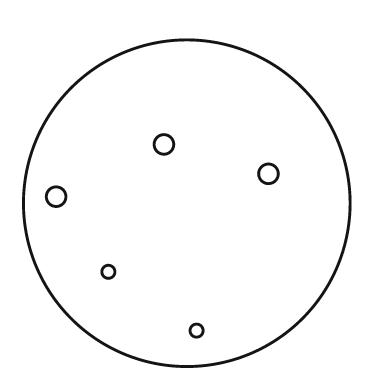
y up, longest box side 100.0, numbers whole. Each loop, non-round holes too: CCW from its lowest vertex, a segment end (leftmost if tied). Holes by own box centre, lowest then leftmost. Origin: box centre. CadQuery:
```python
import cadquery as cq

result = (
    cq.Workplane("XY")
    .moveTo(0.0, 0.0)
    .circle(50.0)
    .moveTo(3.0, -39.0)
    .circle(2.0)
    .moveTo(-24.0, -21.0)
    .circle(2.0)
    .moveTo(-40.0, 2.0)
    .circle(3.0)
    .moveTo(25.0, 9.0)
    .circle(3.0)
    .moveTo(-7.0, 18.0)
    .circle(3.0)
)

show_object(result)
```